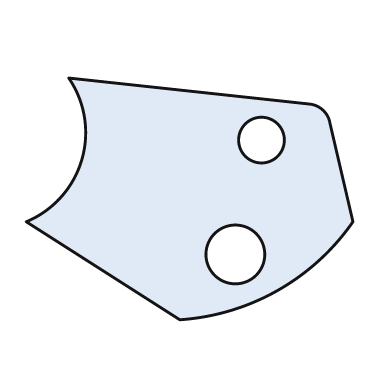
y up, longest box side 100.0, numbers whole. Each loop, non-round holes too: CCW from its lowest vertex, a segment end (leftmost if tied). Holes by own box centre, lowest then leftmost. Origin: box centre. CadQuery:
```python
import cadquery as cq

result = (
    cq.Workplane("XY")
    .moveTo(-3.0, -37.0)
    .threePointArc((27.0, -28.0), (50.0, -7.0))
    .lineTo(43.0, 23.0)
    .threePointArc((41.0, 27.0), (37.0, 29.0))
    .lineTo(-37.0, 37.0)
    .threePointArc((-33.0, 12.0), (-50.0, -7.0))
    .close()
    .moveTo(14.0, -17.0)
    .circle(9.0)
    .moveTo(22.0, 18.0)
    .circle(7.0)
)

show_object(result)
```